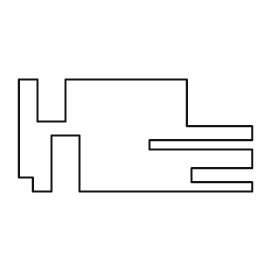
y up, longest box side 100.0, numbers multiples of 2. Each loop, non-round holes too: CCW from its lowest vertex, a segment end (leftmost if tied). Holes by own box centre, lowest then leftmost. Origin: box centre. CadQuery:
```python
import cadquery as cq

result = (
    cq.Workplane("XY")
    .moveTo(-44.0, -24.0)
    .lineTo(-36.0, -24.0)
    .lineTo(-36.0, 0.0)
    .lineTo(-24.0, 0.0)
    .lineTo(-24.0, -24.0)
    .lineTo(50.0, -24.0)
    .lineTo(50.0, -20.0)
    .lineTo(24.0, -20.0)
    .lineTo(24.0, -14.0)
    .lineTo(50.0, -14.0)
    .lineTo(50.0, -6.0)
    .lineTo(6.0, -6.0)
    .lineTo(6.0, -2.0)
    .lineTo(50.0, -2.0)
    .lineTo(50.0, 4.0)
    .lineTo(22.0, 4.0)
    .lineTo(22.0, 24.0)
    .lineTo(-30.0, 24.0)
    .lineTo(-30.0, 6.0)
    .lineTo(-42.0, 6.0)
    .lineTo(-42.0, 24.0)
    .lineTo(-50.0, 24.0)
    .lineTo(-50.0, -18.0)
    .lineTo(-44.0, -18.0)
    .close()
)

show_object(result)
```